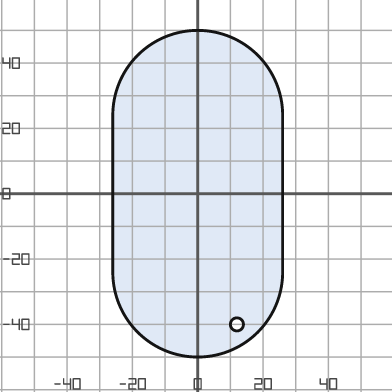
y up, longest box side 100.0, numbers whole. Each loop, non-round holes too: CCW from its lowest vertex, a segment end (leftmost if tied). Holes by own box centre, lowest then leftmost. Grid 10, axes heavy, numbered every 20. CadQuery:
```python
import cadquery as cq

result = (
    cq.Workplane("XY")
    .moveTo(-26.0, -24.0)
    .threePointArc((0.0, -50.0), (26.0, -24.0))
    .lineTo(26.0, 24.0)
    .threePointArc((0.0, 50.0), (-26.0, 24.0))
    .close()
    .moveTo(12.0, -40.0)
    .circle(2.0)
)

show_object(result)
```